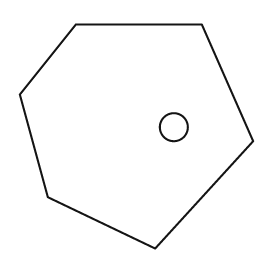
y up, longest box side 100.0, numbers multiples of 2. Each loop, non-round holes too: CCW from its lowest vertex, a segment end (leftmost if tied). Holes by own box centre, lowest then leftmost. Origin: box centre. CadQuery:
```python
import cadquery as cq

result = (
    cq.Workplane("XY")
    .moveTo(8.0, -48.0)
    .lineTo(50.0, -2.0)
    .lineTo(28.0, 48.0)
    .lineTo(-26.0, 48.0)
    .lineTo(-50.0, 18.0)
    .lineTo(-38.0, -26.0)
    .close()
    .moveTo(16.0, 4.0)
    .circle(6.0)
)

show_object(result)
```